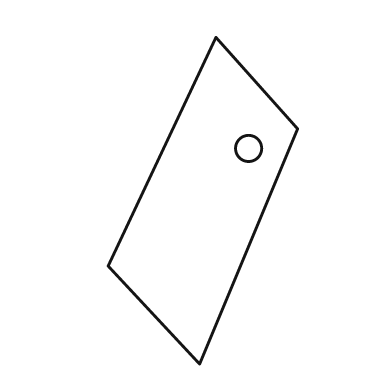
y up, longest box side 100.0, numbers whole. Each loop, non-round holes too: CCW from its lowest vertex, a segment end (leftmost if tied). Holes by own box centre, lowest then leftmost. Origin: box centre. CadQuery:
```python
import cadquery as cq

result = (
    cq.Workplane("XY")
    .moveTo(-1.0, -50.0)
    .lineTo(29.0, 22.0)
    .lineTo(4.0, 50.0)
    .lineTo(-29.0, -20.0)
    .close()
    .moveTo(14.0, 16.0)
    .circle(4.0)
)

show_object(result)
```